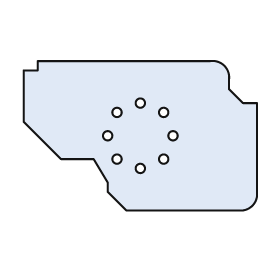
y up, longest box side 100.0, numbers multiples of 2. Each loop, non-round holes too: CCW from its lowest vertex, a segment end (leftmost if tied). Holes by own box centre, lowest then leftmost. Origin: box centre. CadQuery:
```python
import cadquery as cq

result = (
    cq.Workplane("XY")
    .moveTo(-6.0, -32.0)
    .lineTo(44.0, -32.0)
    .threePointArc((48.0, -30.0), (50.0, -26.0))
    .lineTo(50.0, 14.0)
    .lineTo(44.0, 14.0)
    .lineTo(38.0, 20.0)
    .lineTo(38.0, 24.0)
    .threePointArc((36.0, 30.0), (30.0, 32.0))
    .lineTo(-44.0, 32.0)
    .lineTo(-44.0, 28.0)
    .lineTo(-50.0, 28.0)
    .lineTo(-50.0, 6.0)
    .lineTo(-34.0, -10.0)
    .lineTo(-20.0, -10.0)
    .lineTo(-14.0, -20.0)
    .lineTo(-14.0, -24.0)
    .close()
    .moveTo(0.0, -14.0)
    .circle(2.0)
    .moveTo(-10.0, -10.0)
    .circle(2.0)
    .moveTo(10.0, -10.0)
    .circle(2.0)
    .moveTo(-14.0, 0.0)
    .circle(2.0)
    .moveTo(14.0, 0.0)
    .circle(2.0)
    .moveTo(-10.0, 10.0)
    .circle(2.0)
    .moveTo(10.0, 10.0)
    .circle(2.0)
    .moveTo(0.0, 14.0)
    .circle(2.0)
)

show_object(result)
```